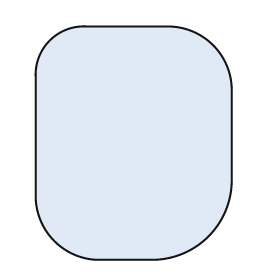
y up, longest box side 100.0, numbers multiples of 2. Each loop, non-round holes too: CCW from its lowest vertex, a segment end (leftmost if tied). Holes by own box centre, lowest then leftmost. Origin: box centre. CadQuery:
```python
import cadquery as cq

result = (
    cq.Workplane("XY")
    .moveTo(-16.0, -50.0)
    .lineTo(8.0, -50.0)
    .threePointArc((32.0, -40.0), (42.0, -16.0))
    .lineTo(42.0, 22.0)
    .threePointArc((34.0, 42.0), (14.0, 50.0))
    .lineTo(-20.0, 50.0)
    .threePointArc((-36.0, 44.0), (-42.0, 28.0))
    .lineTo(-42.0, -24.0)
    .threePointArc((-34.0, -42.0), (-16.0, -50.0))
    .close()
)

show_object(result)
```